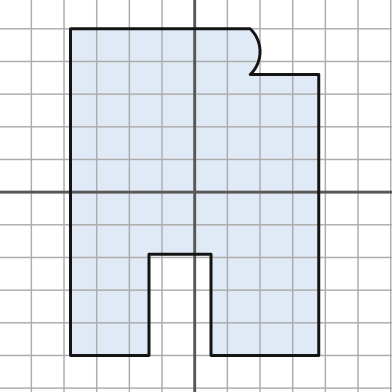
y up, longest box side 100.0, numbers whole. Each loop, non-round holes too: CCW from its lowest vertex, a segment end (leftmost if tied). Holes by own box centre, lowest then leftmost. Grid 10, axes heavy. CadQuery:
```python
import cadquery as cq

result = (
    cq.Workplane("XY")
    .moveTo(-38.0, -50.0)
    .lineTo(-14.0, -50.0)
    .lineTo(-14.0, -19.0)
    .lineTo(5.0, -19.0)
    .lineTo(5.0, -50.0)
    .lineTo(38.0, -50.0)
    .lineTo(38.0, 36.0)
    .lineTo(17.0, 36.0)
    .threePointArc((20.0, 43.0), (17.0, 50.0))
    .lineTo(-38.0, 50.0)
    .close()
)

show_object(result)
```